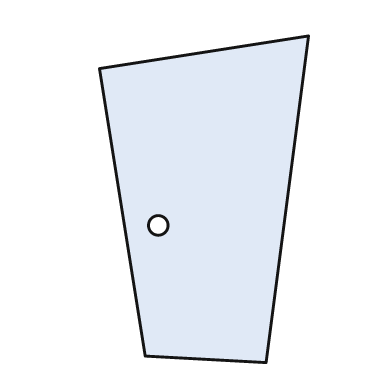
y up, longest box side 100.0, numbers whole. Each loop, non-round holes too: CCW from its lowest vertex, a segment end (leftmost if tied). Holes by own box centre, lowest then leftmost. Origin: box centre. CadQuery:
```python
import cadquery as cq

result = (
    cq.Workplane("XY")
    .moveTo(19.0, -50.0)
    .lineTo(32.0, 50.0)
    .lineTo(-32.0, 40.0)
    .lineTo(-18.0, -48.0)
    .close()
    .moveTo(-14.0, -8.0)
    .circle(3.0)
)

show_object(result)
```